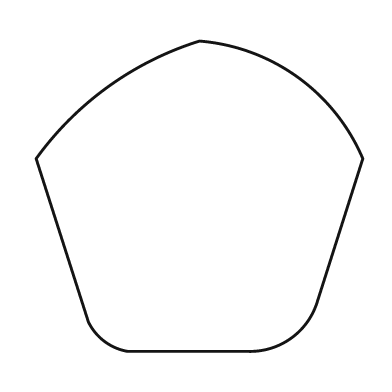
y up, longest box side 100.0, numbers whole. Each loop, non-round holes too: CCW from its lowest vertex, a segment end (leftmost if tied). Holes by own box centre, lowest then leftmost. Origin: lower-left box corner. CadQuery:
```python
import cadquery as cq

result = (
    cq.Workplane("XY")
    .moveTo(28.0, 0.0)
    .lineTo(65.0, 0.0)
    .threePointArc((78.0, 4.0), (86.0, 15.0))
    .lineTo(100.0, 59.0)
    .threePointArc((80.0, 84.0), (50.0, 95.0))
    .threePointArc((22.0, 81.0), (0.0, 59.0))
    .lineTo(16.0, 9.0)
    .threePointArc((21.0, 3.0), (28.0, 0.0))
    .close()
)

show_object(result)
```